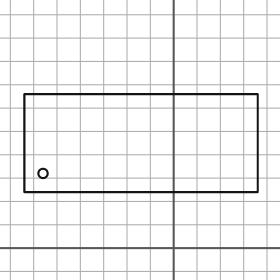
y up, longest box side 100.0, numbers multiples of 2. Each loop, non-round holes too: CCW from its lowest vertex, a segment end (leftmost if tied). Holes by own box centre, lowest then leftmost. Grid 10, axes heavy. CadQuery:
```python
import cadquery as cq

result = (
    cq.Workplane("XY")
    .moveTo(-64.0, 24.0)
    .lineTo(36.0, 24.0)
    .lineTo(36.0, 66.0)
    .lineTo(-64.0, 66.0)
    .close()
    .moveTo(-56.0, 32.0)
    .circle(2.0)
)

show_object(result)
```